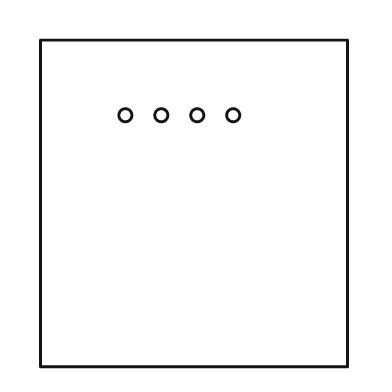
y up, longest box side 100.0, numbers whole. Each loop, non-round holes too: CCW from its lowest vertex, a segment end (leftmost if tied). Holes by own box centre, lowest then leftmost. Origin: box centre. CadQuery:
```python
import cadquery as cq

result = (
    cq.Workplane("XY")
    .moveTo(-47.0, -50.0)
    .lineTo(47.0, -50.0)
    .lineTo(47.0, 50.0)
    .lineTo(-47.0, 50.0)
    .close()
    .moveTo(-21.0, 27.0)
    .circle(2.0)
    .moveTo(-10.0, 27.0)
    .circle(2.0)
    .moveTo(1.0, 27.0)
    .circle(2.0)
    .moveTo(12.0, 27.0)
    .circle(2.0)
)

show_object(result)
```